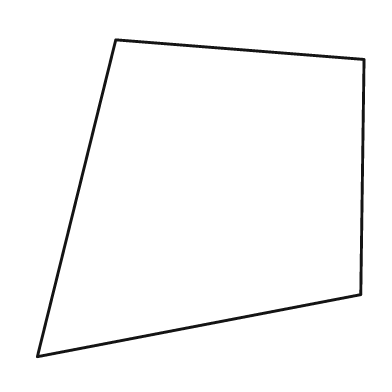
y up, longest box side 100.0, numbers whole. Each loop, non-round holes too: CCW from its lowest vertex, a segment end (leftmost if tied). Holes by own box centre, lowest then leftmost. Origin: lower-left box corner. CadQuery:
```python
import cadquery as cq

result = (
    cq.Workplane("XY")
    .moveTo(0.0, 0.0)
    .lineTo(99.0, 19.0)
    .lineTo(100.0, 91.0)
    .lineTo(24.0, 97.0)
    .close()
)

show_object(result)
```